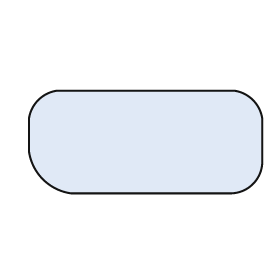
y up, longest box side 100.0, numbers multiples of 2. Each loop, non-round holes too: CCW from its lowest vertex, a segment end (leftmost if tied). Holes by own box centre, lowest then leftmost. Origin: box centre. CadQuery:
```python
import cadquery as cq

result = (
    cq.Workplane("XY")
    .moveTo(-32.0, -22.0)
    .lineTo(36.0, -22.0)
    .threePointArc((46.0, -18.0), (50.0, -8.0))
    .lineTo(50.0, 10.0)
    .threePointArc((46.0, 18.0), (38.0, 22.0))
    .lineTo(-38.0, 22.0)
    .threePointArc((-46.0, 18.0), (-50.0, 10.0))
    .lineTo(-50.0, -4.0)
    .threePointArc((-44.0, -16.0), (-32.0, -22.0))
    .close()
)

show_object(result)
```